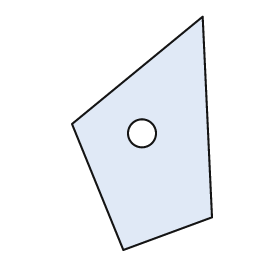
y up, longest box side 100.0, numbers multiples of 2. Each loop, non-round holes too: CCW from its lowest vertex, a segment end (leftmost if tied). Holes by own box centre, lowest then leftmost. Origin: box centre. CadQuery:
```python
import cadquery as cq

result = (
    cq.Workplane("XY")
    .moveTo(-8.0, -50.0)
    .lineTo(30.0, -36.0)
    .lineTo(26.0, 50.0)
    .lineTo(-30.0, 4.0)
    .close()
    .moveTo(0.0, 0.0)
    .circle(6.0)
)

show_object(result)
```